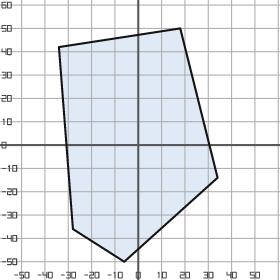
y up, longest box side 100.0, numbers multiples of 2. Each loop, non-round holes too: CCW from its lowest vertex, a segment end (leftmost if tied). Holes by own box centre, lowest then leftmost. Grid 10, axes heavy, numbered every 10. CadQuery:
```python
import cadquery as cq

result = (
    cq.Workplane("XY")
    .moveTo(-6.0, -50.0)
    .lineTo(34.0, -14.0)
    .lineTo(18.0, 50.0)
    .lineTo(-34.0, 42.0)
    .lineTo(-28.0, -36.0)
    .close()
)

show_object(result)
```